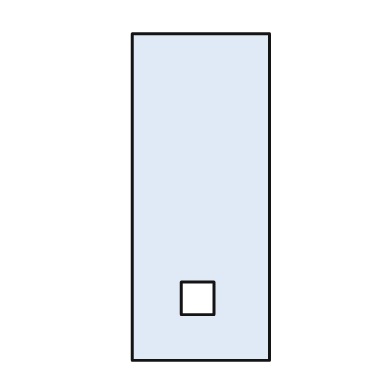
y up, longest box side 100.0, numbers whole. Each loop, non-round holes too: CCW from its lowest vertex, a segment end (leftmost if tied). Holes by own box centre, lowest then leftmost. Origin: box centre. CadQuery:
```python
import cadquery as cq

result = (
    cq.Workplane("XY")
    .moveTo(-21.0, -50.0)
    .lineTo(21.0, -50.0)
    .lineTo(21.0, 50.0)
    .lineTo(-21.0, 50.0)
    .close()
    .moveTo(-6.0, -36.0)
    .lineTo(4.0, -36.0)
    .lineTo(4.0, -26.0)
    .lineTo(-6.0, -26.0)
    .close()
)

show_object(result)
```